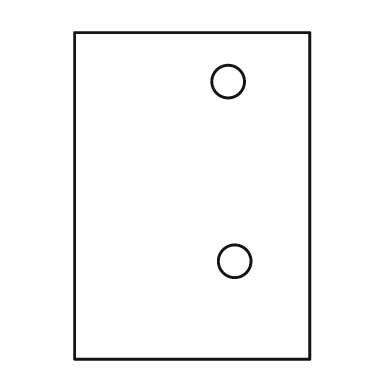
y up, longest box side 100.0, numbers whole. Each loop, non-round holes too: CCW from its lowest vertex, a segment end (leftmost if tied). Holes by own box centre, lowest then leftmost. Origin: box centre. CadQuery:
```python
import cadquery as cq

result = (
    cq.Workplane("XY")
    .moveTo(-36.0, -50.0)
    .lineTo(36.0, -50.0)
    .lineTo(36.0, 50.0)
    .lineTo(-36.0, 50.0)
    .close()
    .moveTo(13.0, -20.0)
    .circle(5.0)
    .moveTo(11.0, 35.0)
    .circle(5.0)
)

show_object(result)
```